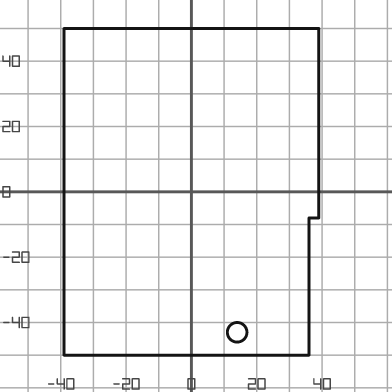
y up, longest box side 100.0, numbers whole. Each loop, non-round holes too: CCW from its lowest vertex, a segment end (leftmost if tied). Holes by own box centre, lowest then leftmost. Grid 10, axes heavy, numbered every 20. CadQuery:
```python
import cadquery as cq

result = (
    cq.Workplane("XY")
    .moveTo(-39.0, -50.0)
    .lineTo(36.0, -50.0)
    .lineTo(36.0, -8.0)
    .lineTo(39.0, -8.0)
    .lineTo(39.0, 50.0)
    .lineTo(-39.0, 50.0)
    .close()
    .moveTo(14.0, -43.0)
    .circle(3.0)
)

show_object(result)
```